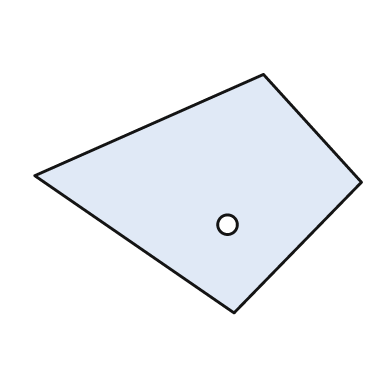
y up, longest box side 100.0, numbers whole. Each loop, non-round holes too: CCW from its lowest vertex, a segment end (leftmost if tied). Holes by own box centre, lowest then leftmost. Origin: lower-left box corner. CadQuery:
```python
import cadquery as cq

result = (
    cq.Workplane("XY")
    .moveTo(61.0, 0.0)
    .lineTo(100.0, 40.0)
    .lineTo(70.0, 73.0)
    .lineTo(0.0, 42.0)
    .close()
    .moveTo(59.0, 27.0)
    .circle(3.0)
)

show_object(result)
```